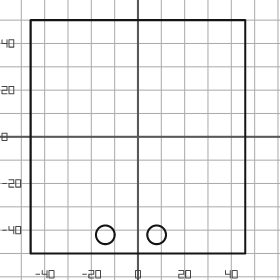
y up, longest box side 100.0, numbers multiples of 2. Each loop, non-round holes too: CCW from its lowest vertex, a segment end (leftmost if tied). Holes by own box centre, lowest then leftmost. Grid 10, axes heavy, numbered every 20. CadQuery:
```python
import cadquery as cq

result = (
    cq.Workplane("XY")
    .moveTo(-46.0, -50.0)
    .lineTo(46.0, -50.0)
    .lineTo(46.0, 50.0)
    .lineTo(-46.0, 50.0)
    .close()
    .moveTo(-14.0, -42.0)
    .circle(4.0)
    .moveTo(8.0, -42.0)
    .circle(4.0)
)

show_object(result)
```